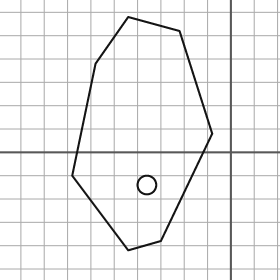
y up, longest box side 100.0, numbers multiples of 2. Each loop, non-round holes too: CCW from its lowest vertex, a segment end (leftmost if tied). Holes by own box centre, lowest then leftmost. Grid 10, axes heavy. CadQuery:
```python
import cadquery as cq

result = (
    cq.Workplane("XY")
    .moveTo(-44.0, -42.0)
    .lineTo(-30.0, -38.0)
    .lineTo(-8.0, 8.0)
    .lineTo(-22.0, 52.0)
    .lineTo(-44.0, 58.0)
    .lineTo(-58.0, 38.0)
    .lineTo(-68.0, -10.0)
    .close()
    .moveTo(-36.0, -14.0)
    .circle(4.0)
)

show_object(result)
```